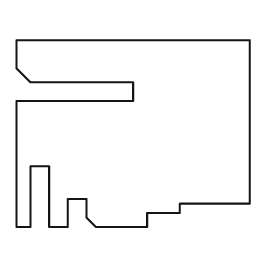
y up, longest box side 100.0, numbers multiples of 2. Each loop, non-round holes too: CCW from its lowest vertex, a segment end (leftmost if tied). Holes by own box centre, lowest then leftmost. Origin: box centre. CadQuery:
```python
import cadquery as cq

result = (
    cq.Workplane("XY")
    .moveTo(-50.0, -40.0)
    .lineTo(-44.0, -40.0)
    .lineTo(-44.0, -14.0)
    .lineTo(-36.0, -14.0)
    .lineTo(-36.0, -40.0)
    .lineTo(-28.0, -40.0)
    .lineTo(-28.0, -28.0)
    .lineTo(-20.0, -28.0)
    .lineTo(-20.0, -36.0)
    .lineTo(-16.0, -40.0)
    .lineTo(6.0, -40.0)
    .lineTo(6.0, -34.0)
    .lineTo(20.0, -34.0)
    .lineTo(20.0, -30.0)
    .lineTo(50.0, -30.0)
    .lineTo(50.0, 40.0)
    .lineTo(-50.0, 40.0)
    .lineTo(-50.0, 28.0)
    .lineTo(-44.0, 22.0)
    .lineTo(0.0, 22.0)
    .lineTo(0.0, 14.0)
    .lineTo(-50.0, 14.0)
    .close()
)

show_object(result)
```